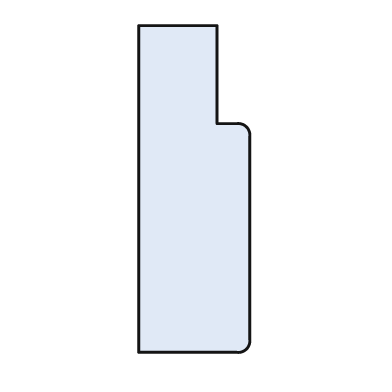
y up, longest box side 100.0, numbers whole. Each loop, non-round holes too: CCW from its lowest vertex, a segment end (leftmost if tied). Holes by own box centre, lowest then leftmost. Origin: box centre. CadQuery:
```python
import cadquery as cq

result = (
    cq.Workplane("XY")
    .moveTo(-17.0, -50.0)
    .lineTo(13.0, -50.0)
    .threePointArc((16.0, -49.0), (17.0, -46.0))
    .lineTo(17.0, 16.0)
    .threePointArc((16.0, 19.0), (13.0, 20.0))
    .lineTo(7.0, 20.0)
    .lineTo(7.0, 50.0)
    .lineTo(-17.0, 50.0)
    .close()
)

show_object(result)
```